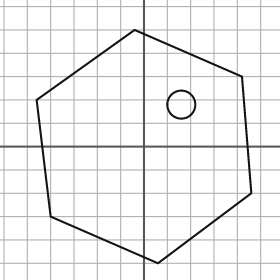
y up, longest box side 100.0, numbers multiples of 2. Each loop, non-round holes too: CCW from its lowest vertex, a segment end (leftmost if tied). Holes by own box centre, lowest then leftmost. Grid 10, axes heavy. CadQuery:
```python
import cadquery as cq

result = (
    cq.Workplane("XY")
    .moveTo(6.0, -50.0)
    .lineTo(46.0, -20.0)
    .lineTo(42.0, 30.0)
    .lineTo(-4.0, 50.0)
    .lineTo(-46.0, 20.0)
    .lineTo(-40.0, -30.0)
    .close()
    .moveTo(16.0, 18.0)
    .circle(6.0)
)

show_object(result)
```